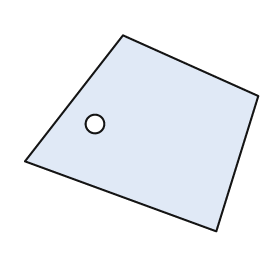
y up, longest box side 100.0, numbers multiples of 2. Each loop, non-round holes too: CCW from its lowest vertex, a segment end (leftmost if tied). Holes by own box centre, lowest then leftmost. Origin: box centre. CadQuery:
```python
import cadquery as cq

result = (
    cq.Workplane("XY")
    .moveTo(32.0, -42.0)
    .lineTo(50.0, 16.0)
    .lineTo(-8.0, 42.0)
    .lineTo(-50.0, -12.0)
    .close()
    .moveTo(-20.0, 4.0)
    .circle(4.0)
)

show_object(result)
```